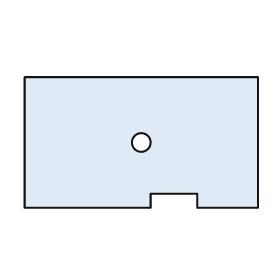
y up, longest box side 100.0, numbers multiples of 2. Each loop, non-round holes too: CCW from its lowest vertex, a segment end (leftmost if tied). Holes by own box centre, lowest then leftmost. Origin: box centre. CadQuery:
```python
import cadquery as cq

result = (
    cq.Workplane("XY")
    .moveTo(-50.0, -28.0)
    .lineTo(4.0, -28.0)
    .lineTo(4.0, -22.0)
    .lineTo(24.0, -22.0)
    .lineTo(24.0, -28.0)
    .lineTo(50.0, -28.0)
    .lineTo(50.0, 28.0)
    .lineTo(-50.0, 28.0)
    .close()
    .moveTo(0.0, 0.0)
    .circle(4.0)
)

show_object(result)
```